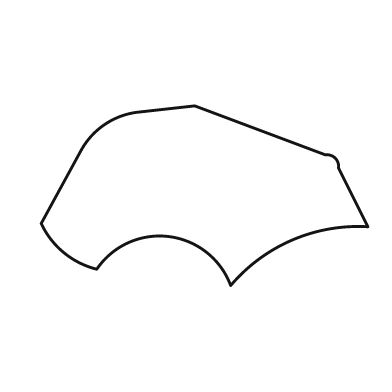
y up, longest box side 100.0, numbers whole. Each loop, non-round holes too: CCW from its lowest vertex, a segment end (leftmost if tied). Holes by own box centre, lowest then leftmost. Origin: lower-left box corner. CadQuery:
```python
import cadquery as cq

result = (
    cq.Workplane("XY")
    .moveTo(58.0, 0.0)
    .threePointArc((77.0, 14.0), (100.0, 18.0))
    .lineTo(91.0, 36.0)
    .threePointArc((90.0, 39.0), (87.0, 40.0))
    .lineTo(47.0, 55.0)
    .lineTo(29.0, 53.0)
    .threePointArc((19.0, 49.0), (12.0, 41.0))
    .lineTo(0.0, 19.0)
    .threePointArc((7.0, 10.0), (17.0, 5.0))
    .threePointArc((39.0, 15.0), (58.0, 0.0))
    .close()
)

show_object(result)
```